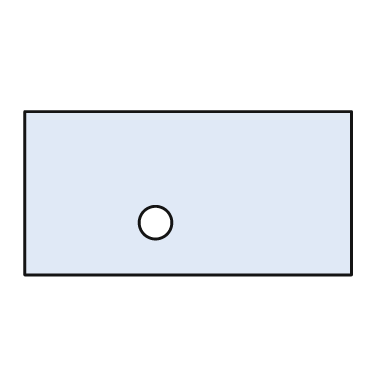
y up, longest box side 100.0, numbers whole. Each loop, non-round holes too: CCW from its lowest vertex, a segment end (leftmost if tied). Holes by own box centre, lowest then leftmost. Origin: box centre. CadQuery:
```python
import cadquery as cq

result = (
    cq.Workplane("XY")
    .moveTo(-50.0, -25.0)
    .lineTo(50.0, -25.0)
    .lineTo(50.0, 25.0)
    .lineTo(-50.0, 25.0)
    .close()
    .moveTo(-10.0, -9.0)
    .circle(5.0)
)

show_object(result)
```